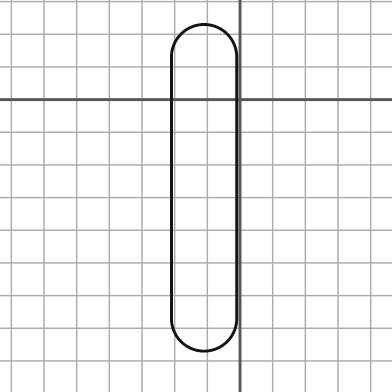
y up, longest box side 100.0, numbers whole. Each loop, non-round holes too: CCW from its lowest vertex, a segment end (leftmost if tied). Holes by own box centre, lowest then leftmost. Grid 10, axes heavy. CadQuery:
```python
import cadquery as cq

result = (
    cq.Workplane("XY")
    .moveTo(-21.0, -67.0)
    .threePointArc((-11.0, -77.0), (-1.0, -67.0))
    .lineTo(-1.0, 13.0)
    .threePointArc((-11.0, 23.0), (-21.0, 13.0))
    .close()
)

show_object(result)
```